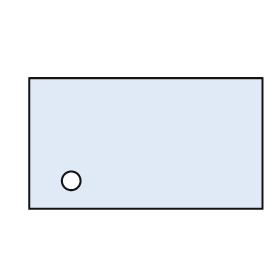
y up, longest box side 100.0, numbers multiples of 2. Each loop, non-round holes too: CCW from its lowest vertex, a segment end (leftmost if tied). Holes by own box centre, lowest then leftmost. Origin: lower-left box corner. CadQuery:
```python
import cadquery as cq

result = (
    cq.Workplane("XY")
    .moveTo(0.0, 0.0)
    .lineTo(100.0, 0.0)
    .lineTo(100.0, 56.0)
    .lineTo(0.0, 56.0)
    .close()
    .moveTo(18.0, 12.0)
    .circle(4.0)
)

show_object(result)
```